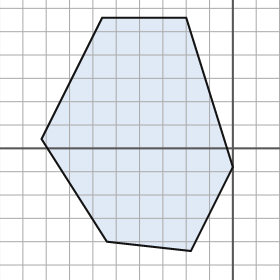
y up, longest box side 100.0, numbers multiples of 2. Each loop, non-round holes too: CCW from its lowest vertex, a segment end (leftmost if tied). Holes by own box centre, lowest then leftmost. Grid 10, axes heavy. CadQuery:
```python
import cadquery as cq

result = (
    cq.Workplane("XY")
    .moveTo(-18.0, -44.0)
    .lineTo(0.0, -8.0)
    .lineTo(-20.0, 56.0)
    .lineTo(-56.0, 56.0)
    .lineTo(-82.0, 4.0)
    .lineTo(-54.0, -40.0)
    .close()
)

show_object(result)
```